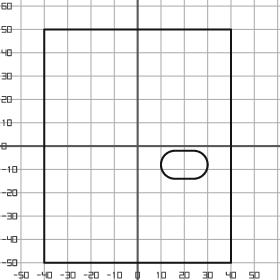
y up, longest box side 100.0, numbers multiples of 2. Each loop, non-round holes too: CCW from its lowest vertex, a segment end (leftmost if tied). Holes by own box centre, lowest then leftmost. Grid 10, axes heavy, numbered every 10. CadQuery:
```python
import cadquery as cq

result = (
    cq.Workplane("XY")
    .moveTo(-40.0, -50.0)
    .lineTo(40.0, -50.0)
    .lineTo(40.0, 50.0)
    .lineTo(-40.0, 50.0)
    .close()
    .moveTo(16.0, -14.0)
    .lineTo(24.0, -14.0)
    .threePointArc((30.0, -8.0), (24.0, -2.0))
    .lineTo(16.0, -2.0)
    .threePointArc((10.0, -8.0), (16.0, -14.0))
    .close()
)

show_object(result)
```